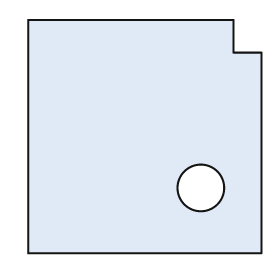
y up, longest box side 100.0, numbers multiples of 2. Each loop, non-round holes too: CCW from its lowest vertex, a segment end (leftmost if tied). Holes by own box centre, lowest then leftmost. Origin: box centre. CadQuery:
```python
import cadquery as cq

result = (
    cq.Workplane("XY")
    .moveTo(-50.0, -50.0)
    .lineTo(50.0, -50.0)
    .lineTo(50.0, 36.0)
    .lineTo(38.0, 36.0)
    .lineTo(38.0, 50.0)
    .lineTo(-50.0, 50.0)
    .close()
    .moveTo(24.0, -22.0)
    .circle(10.0)
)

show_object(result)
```